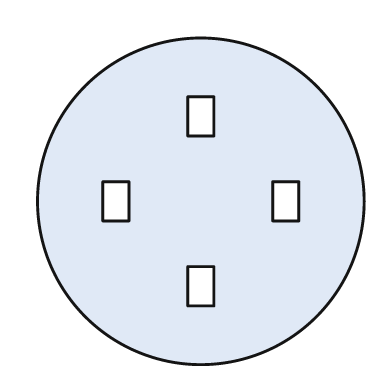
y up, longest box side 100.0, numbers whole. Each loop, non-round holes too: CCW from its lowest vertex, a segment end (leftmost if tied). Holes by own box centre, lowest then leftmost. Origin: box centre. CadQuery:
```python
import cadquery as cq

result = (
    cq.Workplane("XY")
    .moveTo(0.0, 0.0)
    .circle(50.0)
    .moveTo(-4.0, -32.0)
    .lineTo(4.0, -32.0)
    .lineTo(4.0, -20.0)
    .lineTo(-4.0, -20.0)
    .close()
    .moveTo(-30.0, -6.0)
    .lineTo(-22.0, -6.0)
    .lineTo(-22.0, 6.0)
    .lineTo(-30.0, 6.0)
    .close()
    .moveTo(22.0, -6.0)
    .lineTo(30.0, -6.0)
    .lineTo(30.0, 6.0)
    .lineTo(22.0, 6.0)
    .close()
    .moveTo(-4.0, 20.0)
    .lineTo(4.0, 20.0)
    .lineTo(4.0, 32.0)
    .lineTo(-4.0, 32.0)
    .close()
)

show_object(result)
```